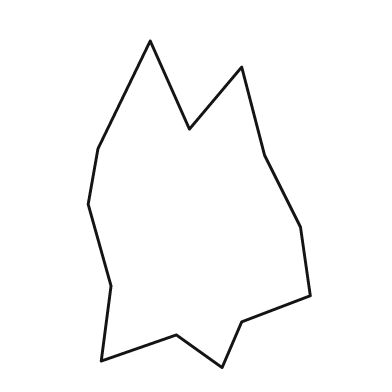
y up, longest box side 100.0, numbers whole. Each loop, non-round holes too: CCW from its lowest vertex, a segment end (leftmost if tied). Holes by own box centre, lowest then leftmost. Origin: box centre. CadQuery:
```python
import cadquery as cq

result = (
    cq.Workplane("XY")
    .moveTo(7.0, -50.0)
    .lineTo(13.0, -36.0)
    .lineTo(34.0, -28.0)
    .lineTo(31.0, -7.0)
    .lineTo(20.0, 15.0)
    .lineTo(13.0, 42.0)
    .lineTo(-3.0, 23.0)
    .lineTo(-15.0, 50.0)
    .lineTo(-31.0, 17.0)
    .lineTo(-34.0, 0.0)
    .lineTo(-27.0, -25.0)
    .lineTo(-30.0, -48.0)
    .lineTo(-7.0, -40.0)
    .close()
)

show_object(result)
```